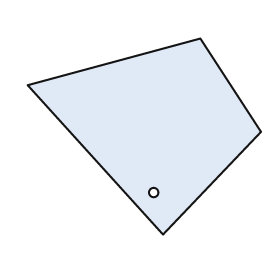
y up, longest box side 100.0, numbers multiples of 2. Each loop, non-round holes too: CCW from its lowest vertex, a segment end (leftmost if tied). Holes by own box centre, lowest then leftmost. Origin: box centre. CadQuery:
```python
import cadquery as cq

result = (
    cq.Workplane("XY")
    .moveTo(8.0, -42.0)
    .lineTo(50.0, 2.0)
    .lineTo(24.0, 42.0)
    .lineTo(-50.0, 22.0)
    .close()
    .moveTo(4.0, -24.0)
    .circle(2.0)
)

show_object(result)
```